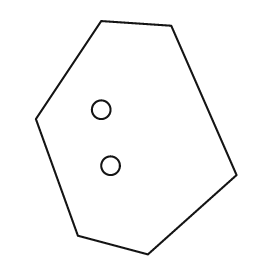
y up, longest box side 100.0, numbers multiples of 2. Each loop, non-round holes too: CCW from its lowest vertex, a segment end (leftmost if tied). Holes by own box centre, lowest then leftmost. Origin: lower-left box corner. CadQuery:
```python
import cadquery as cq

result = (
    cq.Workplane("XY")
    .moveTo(48.0, 0.0)
    .lineTo(86.0, 34.0)
    .lineTo(58.0, 98.0)
    .lineTo(28.0, 100.0)
    .lineTo(0.0, 58.0)
    .lineTo(18.0, 8.0)
    .close()
    .moveTo(32.0, 38.0)
    .circle(4.0)
    .moveTo(28.0, 62.0)
    .circle(4.0)
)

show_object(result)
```